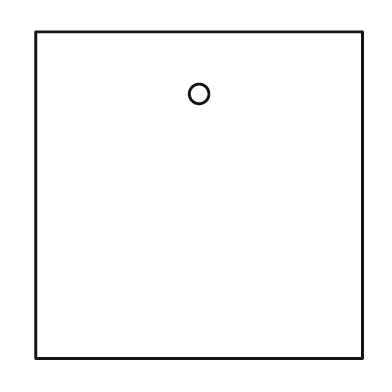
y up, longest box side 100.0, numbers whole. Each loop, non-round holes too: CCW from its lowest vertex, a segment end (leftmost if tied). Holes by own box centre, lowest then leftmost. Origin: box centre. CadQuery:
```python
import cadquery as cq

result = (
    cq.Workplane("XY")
    .moveTo(-50.0, -50.0)
    .lineTo(50.0, -50.0)
    .lineTo(50.0, 50.0)
    .lineTo(-50.0, 50.0)
    .close()
    .moveTo(0.0, 31.0)
    .circle(3.0)
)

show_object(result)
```